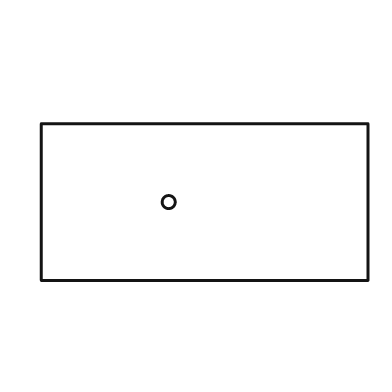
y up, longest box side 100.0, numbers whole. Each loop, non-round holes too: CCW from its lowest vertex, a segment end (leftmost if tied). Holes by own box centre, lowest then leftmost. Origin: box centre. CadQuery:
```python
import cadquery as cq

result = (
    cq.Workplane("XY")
    .moveTo(-50.0, -24.0)
    .lineTo(50.0, -24.0)
    .lineTo(50.0, 24.0)
    .lineTo(-50.0, 24.0)
    .close()
    .moveTo(-11.0, 0.0)
    .circle(2.0)
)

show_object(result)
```